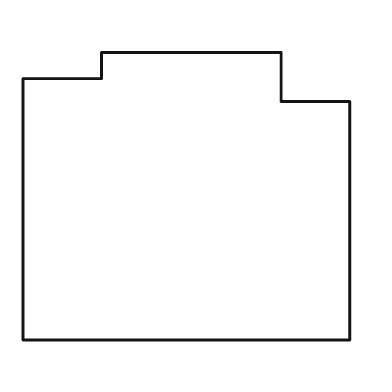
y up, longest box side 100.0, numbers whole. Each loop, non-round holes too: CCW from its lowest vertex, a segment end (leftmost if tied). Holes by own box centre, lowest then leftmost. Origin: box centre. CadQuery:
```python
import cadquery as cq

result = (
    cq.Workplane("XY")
    .moveTo(-50.0, -44.0)
    .lineTo(50.0, -44.0)
    .lineTo(50.0, 29.0)
    .lineTo(29.0, 29.0)
    .lineTo(29.0, 44.0)
    .lineTo(-26.0, 44.0)
    .lineTo(-26.0, 36.0)
    .lineTo(-50.0, 36.0)
    .close()
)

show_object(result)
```